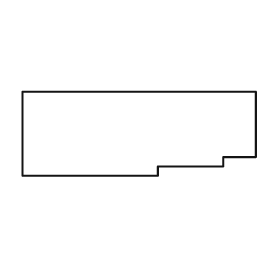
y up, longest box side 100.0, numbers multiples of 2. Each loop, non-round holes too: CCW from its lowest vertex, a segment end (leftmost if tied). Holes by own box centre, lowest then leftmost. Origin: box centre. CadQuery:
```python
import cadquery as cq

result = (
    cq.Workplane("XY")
    .moveTo(-50.0, -18.0)
    .lineTo(8.0, -18.0)
    .lineTo(8.0, -14.0)
    .lineTo(36.0, -14.0)
    .lineTo(36.0, -10.0)
    .lineTo(50.0, -10.0)
    .lineTo(50.0, 18.0)
    .lineTo(-50.0, 18.0)
    .close()
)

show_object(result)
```